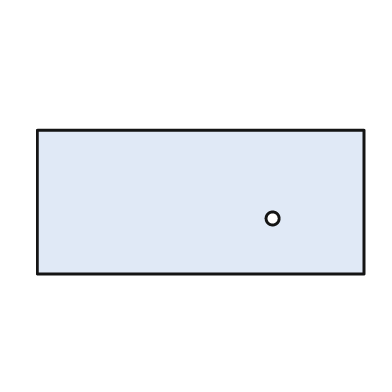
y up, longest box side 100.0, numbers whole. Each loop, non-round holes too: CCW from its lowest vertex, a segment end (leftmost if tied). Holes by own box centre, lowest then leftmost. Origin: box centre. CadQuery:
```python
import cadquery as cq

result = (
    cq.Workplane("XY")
    .moveTo(-50.0, -22.0)
    .lineTo(50.0, -22.0)
    .lineTo(50.0, 22.0)
    .lineTo(-50.0, 22.0)
    .close()
    .moveTo(22.0, -5.0)
    .circle(2.0)
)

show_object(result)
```